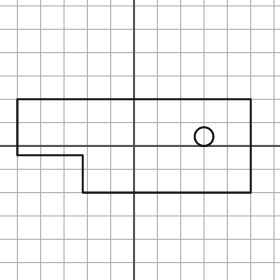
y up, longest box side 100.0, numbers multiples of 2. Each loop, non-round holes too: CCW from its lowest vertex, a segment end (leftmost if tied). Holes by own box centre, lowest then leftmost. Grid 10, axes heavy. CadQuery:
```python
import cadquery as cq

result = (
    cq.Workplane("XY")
    .moveTo(-22.0, -20.0)
    .lineTo(50.0, -20.0)
    .lineTo(50.0, 20.0)
    .lineTo(-50.0, 20.0)
    .lineTo(-50.0, -4.0)
    .lineTo(-22.0, -4.0)
    .close()
    .moveTo(30.0, 4.0)
    .circle(4.0)
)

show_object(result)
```